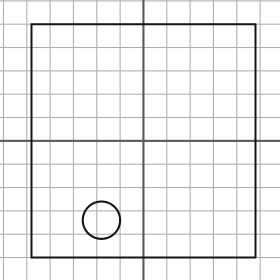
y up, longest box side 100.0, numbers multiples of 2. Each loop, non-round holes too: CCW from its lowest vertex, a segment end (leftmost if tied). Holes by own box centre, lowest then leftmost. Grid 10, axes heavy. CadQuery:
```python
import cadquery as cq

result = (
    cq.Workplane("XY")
    .moveTo(-48.0, -50.0)
    .lineTo(48.0, -50.0)
    .lineTo(48.0, 50.0)
    .lineTo(-48.0, 50.0)
    .close()
    .moveTo(-18.0, -34.0)
    .circle(8.0)
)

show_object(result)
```